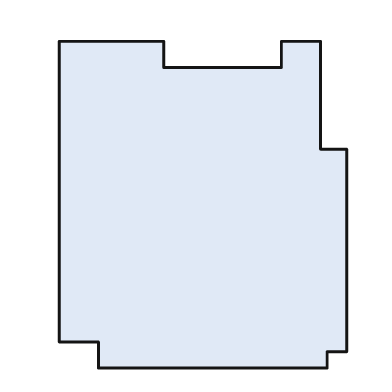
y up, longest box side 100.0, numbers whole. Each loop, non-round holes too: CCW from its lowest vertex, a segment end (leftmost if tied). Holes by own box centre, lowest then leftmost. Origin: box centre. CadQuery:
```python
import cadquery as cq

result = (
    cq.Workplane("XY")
    .moveTo(-32.0, -50.0)
    .lineTo(38.0, -50.0)
    .lineTo(38.0, -45.0)
    .lineTo(44.0, -45.0)
    .lineTo(44.0, 17.0)
    .lineTo(36.0, 17.0)
    .lineTo(36.0, 50.0)
    .lineTo(24.0, 50.0)
    .lineTo(24.0, 42.0)
    .lineTo(-12.0, 42.0)
    .lineTo(-12.0, 50.0)
    .lineTo(-44.0, 50.0)
    .lineTo(-44.0, -42.0)
    .lineTo(-32.0, -42.0)
    .close()
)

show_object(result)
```